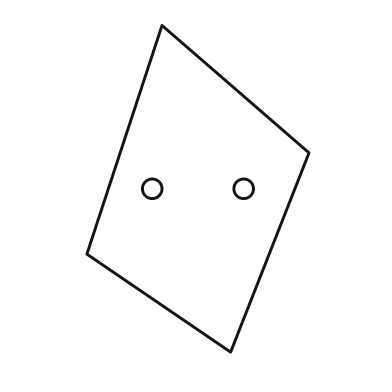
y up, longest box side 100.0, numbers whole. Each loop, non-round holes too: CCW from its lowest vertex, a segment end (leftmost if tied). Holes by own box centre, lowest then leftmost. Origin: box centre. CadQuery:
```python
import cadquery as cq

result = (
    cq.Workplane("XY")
    .moveTo(10.0, -50.0)
    .lineTo(34.0, 11.0)
    .lineTo(-11.0, 50.0)
    .lineTo(-34.0, -20.0)
    .close()
    .moveTo(-14.0, 0.0)
    .circle(3.0)
    .moveTo(14.0, 0.0)
    .circle(3.0)
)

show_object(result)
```